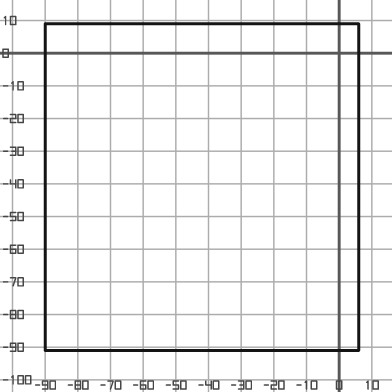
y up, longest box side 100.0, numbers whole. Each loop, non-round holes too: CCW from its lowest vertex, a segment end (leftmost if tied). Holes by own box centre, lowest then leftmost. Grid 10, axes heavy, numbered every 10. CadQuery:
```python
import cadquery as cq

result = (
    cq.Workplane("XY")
    .moveTo(-90.0, -91.0)
    .lineTo(6.0, -91.0)
    .lineTo(6.0, 9.0)
    .lineTo(-90.0, 9.0)
    .close()
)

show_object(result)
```